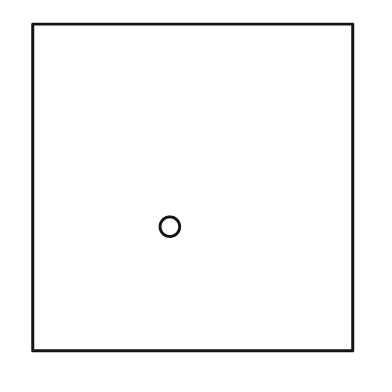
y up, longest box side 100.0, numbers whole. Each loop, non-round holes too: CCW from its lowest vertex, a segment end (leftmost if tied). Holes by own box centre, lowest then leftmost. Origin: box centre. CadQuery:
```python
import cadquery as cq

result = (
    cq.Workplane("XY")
    .moveTo(-49.0, -50.0)
    .lineTo(49.0, -50.0)
    .lineTo(49.0, 50.0)
    .lineTo(-49.0, 50.0)
    .close()
    .moveTo(-7.0, -12.0)
    .circle(3.0)
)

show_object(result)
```